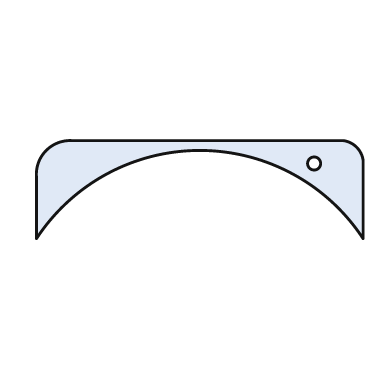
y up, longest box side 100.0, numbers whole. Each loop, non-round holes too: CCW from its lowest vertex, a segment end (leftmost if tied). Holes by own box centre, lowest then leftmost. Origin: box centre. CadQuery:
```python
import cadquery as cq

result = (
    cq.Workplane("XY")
    .moveTo(-50.0, -15.0)
    .threePointArc((0.0, 12.0), (50.0, -15.0))
    .lineTo(50.0, 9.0)
    .threePointArc((48.0, 13.0), (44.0, 15.0))
    .lineTo(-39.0, 15.0)
    .threePointArc((-47.0, 12.0), (-50.0, 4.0))
    .close()
    .moveTo(35.0, 8.0)
    .circle(2.0)
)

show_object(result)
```